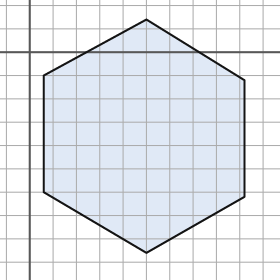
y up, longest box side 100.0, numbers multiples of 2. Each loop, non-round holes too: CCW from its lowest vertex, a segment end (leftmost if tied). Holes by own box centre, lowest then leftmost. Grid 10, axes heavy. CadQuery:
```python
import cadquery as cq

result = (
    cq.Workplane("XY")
    .moveTo(50.0, -86.0)
    .lineTo(92.0, -62.0)
    .lineTo(92.0, -12.0)
    .lineTo(50.0, 14.0)
    .lineTo(6.0, -10.0)
    .lineTo(6.0, -60.0)
    .close()
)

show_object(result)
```